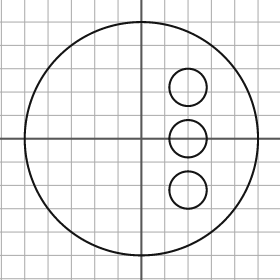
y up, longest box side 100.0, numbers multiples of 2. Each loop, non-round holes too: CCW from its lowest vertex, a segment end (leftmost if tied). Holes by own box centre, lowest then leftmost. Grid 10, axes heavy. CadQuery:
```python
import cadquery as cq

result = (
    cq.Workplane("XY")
    .moveTo(0.0, 0.0)
    .circle(50.0)
    .moveTo(20.0, -22.0)
    .circle(8.0)
    .moveTo(20.0, 0.0)
    .circle(8.0)
    .moveTo(20.0, 22.0)
    .circle(8.0)
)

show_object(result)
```